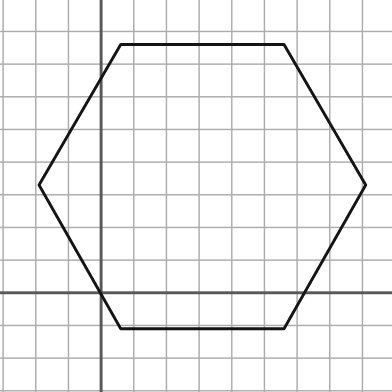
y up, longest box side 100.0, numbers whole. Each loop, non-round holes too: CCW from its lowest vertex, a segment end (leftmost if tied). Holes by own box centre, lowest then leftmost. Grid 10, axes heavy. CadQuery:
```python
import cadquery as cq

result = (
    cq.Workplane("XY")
    .moveTo(6.0, -11.0)
    .lineTo(56.0, -11.0)
    .lineTo(81.0, 33.0)
    .lineTo(56.0, 76.0)
    .lineTo(6.0, 76.0)
    .lineTo(-19.0, 33.0)
    .close()
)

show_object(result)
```